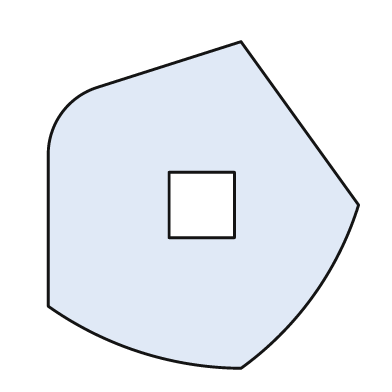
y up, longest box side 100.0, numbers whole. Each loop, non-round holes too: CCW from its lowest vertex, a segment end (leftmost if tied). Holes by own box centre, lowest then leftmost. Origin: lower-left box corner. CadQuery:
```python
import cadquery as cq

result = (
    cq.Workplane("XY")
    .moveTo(59.0, 0.0)
    .threePointArc((81.0, 22.0), (95.0, 50.0))
    .lineTo(59.0, 100.0)
    .lineTo(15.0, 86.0)
    .threePointArc((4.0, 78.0), (0.0, 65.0))
    .lineTo(0.0, 19.0)
    .threePointArc((28.0, 5.0), (59.0, 0.0))
    .close()
    .moveTo(37.0, 40.0)
    .lineTo(57.0, 40.0)
    .lineTo(57.0, 60.0)
    .lineTo(37.0, 60.0)
    .close()
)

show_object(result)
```